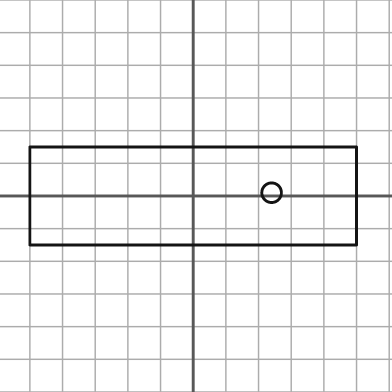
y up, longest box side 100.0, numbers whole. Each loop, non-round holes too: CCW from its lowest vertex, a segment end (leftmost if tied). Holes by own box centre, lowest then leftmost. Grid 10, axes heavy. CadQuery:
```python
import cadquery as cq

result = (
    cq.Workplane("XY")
    .moveTo(-50.0, -15.0)
    .lineTo(50.0, -15.0)
    .lineTo(50.0, 15.0)
    .lineTo(-50.0, 15.0)
    .close()
    .moveTo(24.0, 1.0)
    .circle(3.0)
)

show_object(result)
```